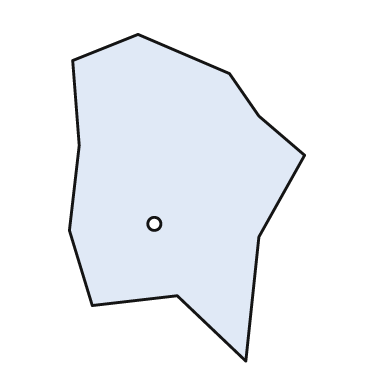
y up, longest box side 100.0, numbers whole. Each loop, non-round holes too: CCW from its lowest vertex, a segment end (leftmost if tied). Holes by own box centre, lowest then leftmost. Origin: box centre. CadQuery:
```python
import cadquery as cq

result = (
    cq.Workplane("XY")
    .moveTo(18.0, -50.0)
    .lineTo(22.0, -12.0)
    .lineTo(36.0, 13.0)
    .lineTo(22.0, 25.0)
    .lineTo(13.0, 38.0)
    .lineTo(-15.0, 50.0)
    .lineTo(-35.0, 42.0)
    .lineTo(-33.0, 16.0)
    .lineTo(-36.0, -10.0)
    .lineTo(-29.0, -33.0)
    .lineTo(-3.0, -30.0)
    .close()
    .moveTo(-10.0, -8.0)
    .circle(2.0)
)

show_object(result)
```